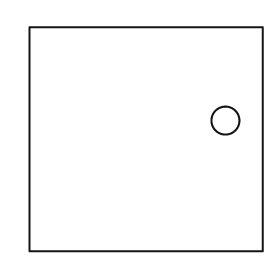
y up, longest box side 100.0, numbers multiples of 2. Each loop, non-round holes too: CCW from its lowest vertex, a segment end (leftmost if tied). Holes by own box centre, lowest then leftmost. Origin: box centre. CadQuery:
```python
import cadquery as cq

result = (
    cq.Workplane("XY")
    .moveTo(-50.0, -48.0)
    .lineTo(50.0, -48.0)
    .lineTo(50.0, 48.0)
    .lineTo(-50.0, 48.0)
    .close()
    .moveTo(34.0, 8.0)
    .circle(6.0)
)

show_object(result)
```